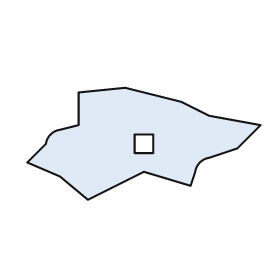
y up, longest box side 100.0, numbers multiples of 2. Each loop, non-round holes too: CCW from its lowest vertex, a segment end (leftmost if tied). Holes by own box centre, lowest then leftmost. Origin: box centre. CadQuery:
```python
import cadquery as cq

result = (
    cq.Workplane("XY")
    .moveTo(-24.0, -24.0)
    .lineTo(0.0, -12.0)
    .lineTo(20.0, -18.0)
    .lineTo(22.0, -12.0)
    .threePointArc((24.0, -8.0), (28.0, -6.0))
    .lineTo(40.0, -2.0)
    .lineTo(50.0, 8.0)
    .lineTo(28.0, 12.0)
    .lineTo(16.0, 18.0)
    .lineTo(-8.0, 24.0)
    .lineTo(-28.0, 22.0)
    .lineTo(-28.0, 8.0)
    .lineTo(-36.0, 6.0)
    .threePointArc((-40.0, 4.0), (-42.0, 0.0))
    .lineTo(-50.0, -8.0)
    .lineTo(-36.0, -14.0)
    .close()
    .moveTo(-4.0, -4.0)
    .lineTo(4.0, -4.0)
    .lineTo(4.0, 4.0)
    .lineTo(-4.0, 4.0)
    .close()
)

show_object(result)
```